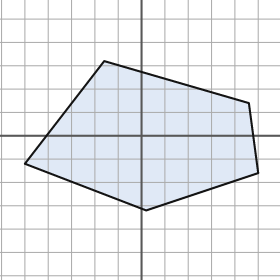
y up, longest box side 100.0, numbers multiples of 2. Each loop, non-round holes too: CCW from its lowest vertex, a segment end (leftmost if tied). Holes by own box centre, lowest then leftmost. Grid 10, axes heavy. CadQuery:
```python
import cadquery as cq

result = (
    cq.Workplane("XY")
    .moveTo(2.0, -32.0)
    .lineTo(50.0, -16.0)
    .lineTo(46.0, 14.0)
    .lineTo(-16.0, 32.0)
    .lineTo(-50.0, -12.0)
    .close()
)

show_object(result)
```